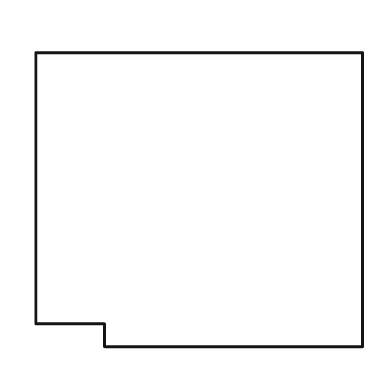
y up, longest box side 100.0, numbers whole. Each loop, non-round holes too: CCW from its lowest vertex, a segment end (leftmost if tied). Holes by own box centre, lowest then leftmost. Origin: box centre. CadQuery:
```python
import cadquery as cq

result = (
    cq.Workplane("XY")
    .moveTo(-29.0, -45.0)
    .lineTo(50.0, -45.0)
    .lineTo(50.0, 45.0)
    .lineTo(-50.0, 45.0)
    .lineTo(-50.0, -38.0)
    .lineTo(-29.0, -38.0)
    .close()
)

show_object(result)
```